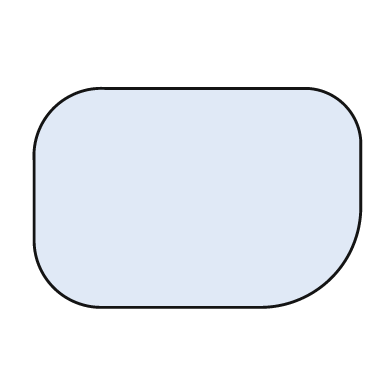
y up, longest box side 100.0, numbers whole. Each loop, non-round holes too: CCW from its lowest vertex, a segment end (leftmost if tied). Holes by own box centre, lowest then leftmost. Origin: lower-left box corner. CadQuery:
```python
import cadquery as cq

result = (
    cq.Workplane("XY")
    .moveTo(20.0, 0.0)
    .lineTo(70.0, 0.0)
    .threePointArc((91.0, 9.0), (100.0, 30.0))
    .lineTo(100.0, 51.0)
    .threePointArc((95.0, 62.0), (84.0, 67.0))
    .lineTo(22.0, 67.0)
    .threePointArc((6.0, 61.0), (0.0, 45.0))
    .lineTo(0.0, 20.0)
    .threePointArc((6.0, 6.0), (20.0, 0.0))
    .close()
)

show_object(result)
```